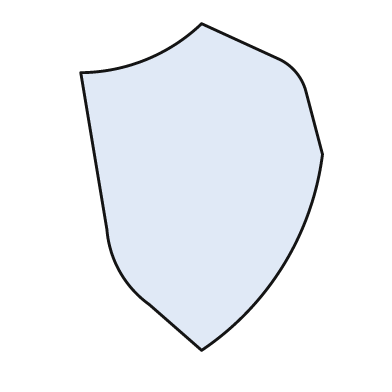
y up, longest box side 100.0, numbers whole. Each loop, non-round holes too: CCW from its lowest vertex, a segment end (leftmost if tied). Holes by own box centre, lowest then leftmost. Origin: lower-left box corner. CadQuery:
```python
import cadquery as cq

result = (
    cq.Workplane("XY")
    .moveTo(37.0, 0.0)
    .threePointArc((62.0, 26.0), (74.0, 60.0))
    .lineTo(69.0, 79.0)
    .threePointArc((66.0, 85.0), (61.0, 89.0))
    .lineTo(37.0, 100.0)
    .threePointArc((20.0, 89.0), (0.0, 85.0))
    .lineTo(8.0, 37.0)
    .threePointArc((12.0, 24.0), (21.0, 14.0))
    .close()
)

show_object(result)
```